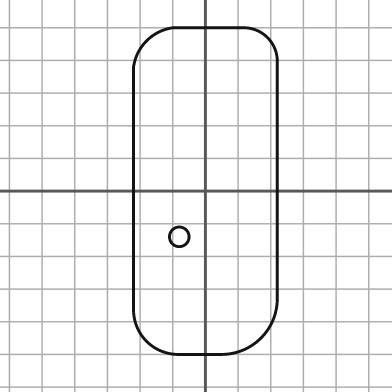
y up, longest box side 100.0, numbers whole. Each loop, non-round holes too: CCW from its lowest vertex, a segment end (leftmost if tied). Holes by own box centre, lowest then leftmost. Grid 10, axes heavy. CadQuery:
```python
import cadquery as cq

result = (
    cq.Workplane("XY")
    .moveTo(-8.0, -50.0)
    .lineTo(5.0, -50.0)
    .threePointArc((17.0, -45.0), (22.0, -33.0))
    .lineTo(22.0, 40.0)
    .threePointArc((19.0, 47.0), (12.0, 50.0))
    .lineTo(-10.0, 50.0)
    .threePointArc((-18.0, 46.0), (-22.0, 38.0))
    .lineTo(-22.0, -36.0)
    .threePointArc((-18.0, -46.0), (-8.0, -50.0))
    .close()
    .moveTo(-8.0, -14.0)
    .circle(3.0)
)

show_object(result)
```